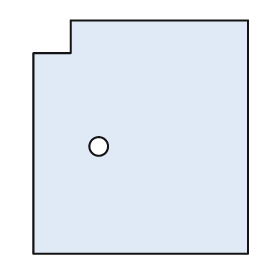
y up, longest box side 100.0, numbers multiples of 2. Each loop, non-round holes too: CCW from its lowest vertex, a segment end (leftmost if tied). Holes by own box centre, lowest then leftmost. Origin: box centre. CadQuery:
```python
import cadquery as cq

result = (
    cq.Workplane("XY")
    .moveTo(-46.0, -50.0)
    .lineTo(46.0, -50.0)
    .lineTo(46.0, 50.0)
    .lineTo(-30.0, 50.0)
    .lineTo(-30.0, 36.0)
    .lineTo(-46.0, 36.0)
    .close()
    .moveTo(-18.0, -4.0)
    .circle(4.0)
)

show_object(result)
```